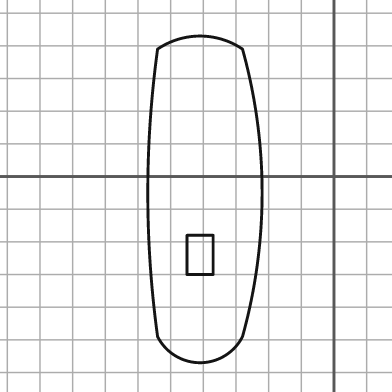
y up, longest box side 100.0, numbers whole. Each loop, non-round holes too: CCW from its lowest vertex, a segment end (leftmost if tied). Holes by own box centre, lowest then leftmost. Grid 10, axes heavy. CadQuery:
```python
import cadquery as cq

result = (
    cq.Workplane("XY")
    .moveTo(-54.0, -49.0)
    .threePointArc((-41.0, -57.0), (-28.0, -49.0))
    .threePointArc((-22.0, -5.0), (-28.0, 39.0))
    .threePointArc((-41.0, 43.0), (-54.0, 39.0))
    .threePointArc((-57.0, -5.0), (-54.0, -49.0))
    .close()
    .moveTo(-45.0, -30.0)
    .lineTo(-37.0, -30.0)
    .lineTo(-37.0, -18.0)
    .lineTo(-45.0, -18.0)
    .close()
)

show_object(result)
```